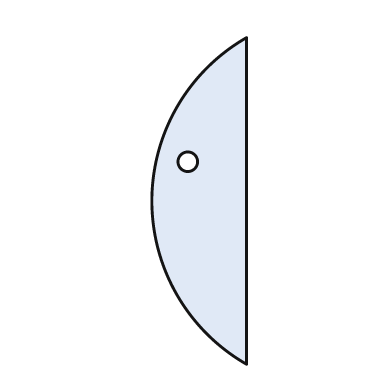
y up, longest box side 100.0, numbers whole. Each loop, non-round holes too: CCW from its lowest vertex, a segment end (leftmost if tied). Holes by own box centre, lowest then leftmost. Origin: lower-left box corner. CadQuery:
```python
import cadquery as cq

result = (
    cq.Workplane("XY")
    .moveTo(29.0, 0.0)
    .lineTo(29.0, 100.0)
    .threePointArc((0.0, 50.0), (29.0, 0.0))
    .close()
    .moveTo(11.0, 62.0)
    .circle(3.0)
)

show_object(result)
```